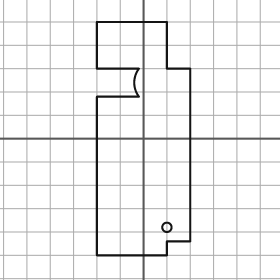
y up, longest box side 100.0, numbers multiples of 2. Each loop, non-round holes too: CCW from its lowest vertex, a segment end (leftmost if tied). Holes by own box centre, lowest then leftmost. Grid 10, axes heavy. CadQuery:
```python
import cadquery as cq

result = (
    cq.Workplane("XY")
    .moveTo(-20.0, -50.0)
    .lineTo(10.0, -50.0)
    .lineTo(10.0, -44.0)
    .lineTo(20.0, -44.0)
    .lineTo(20.0, 30.0)
    .lineTo(10.0, 30.0)
    .lineTo(10.0, 50.0)
    .lineTo(-20.0, 50.0)
    .lineTo(-20.0, 30.0)
    .lineTo(-2.0, 30.0)
    .threePointArc((-4.0, 24.0), (-2.0, 18.0))
    .lineTo(-20.0, 18.0)
    .close()
    .moveTo(10.0, -38.0)
    .circle(2.0)
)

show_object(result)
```